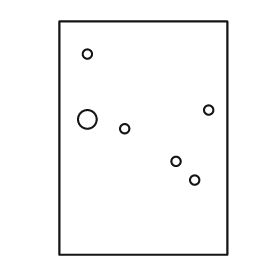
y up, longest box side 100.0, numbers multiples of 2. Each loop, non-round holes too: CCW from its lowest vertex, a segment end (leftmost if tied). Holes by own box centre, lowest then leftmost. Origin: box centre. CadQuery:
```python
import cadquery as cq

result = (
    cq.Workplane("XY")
    .moveTo(-36.0, -50.0)
    .lineTo(36.0, -50.0)
    .lineTo(36.0, 50.0)
    .lineTo(-36.0, 50.0)
    .close()
    .moveTo(22.0, -18.0)
    .circle(2.0)
    .moveTo(14.0, -10.0)
    .circle(2.0)
    .moveTo(-8.0, 4.0)
    .circle(2.0)
    .moveTo(-24.0, 8.0)
    .circle(4.0)
    .moveTo(28.0, 12.0)
    .circle(2.0)
    .moveTo(-24.0, 36.0)
    .circle(2.0)
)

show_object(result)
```